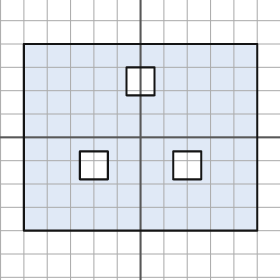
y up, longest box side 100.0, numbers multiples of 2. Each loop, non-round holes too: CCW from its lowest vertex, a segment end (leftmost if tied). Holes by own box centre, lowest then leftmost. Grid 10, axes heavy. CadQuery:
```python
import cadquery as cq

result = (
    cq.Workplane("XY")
    .moveTo(-50.0, -40.0)
    .lineTo(50.0, -40.0)
    .lineTo(50.0, 40.0)
    .lineTo(-50.0, 40.0)
    .close()
    .moveTo(-26.0, -18.0)
    .lineTo(-14.0, -18.0)
    .lineTo(-14.0, -6.0)
    .lineTo(-26.0, -6.0)
    .close()
    .moveTo(14.0, -18.0)
    .lineTo(26.0, -18.0)
    .lineTo(26.0, -6.0)
    .lineTo(14.0, -6.0)
    .close()
    .moveTo(-6.0, 18.0)
    .lineTo(6.0, 18.0)
    .lineTo(6.0, 30.0)
    .lineTo(-6.0, 30.0)
    .close()
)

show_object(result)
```